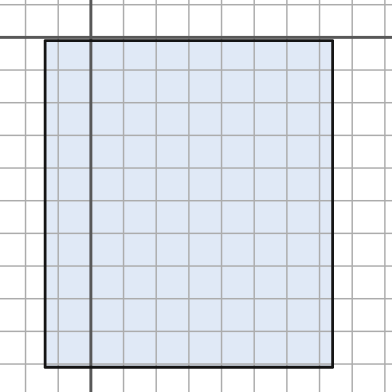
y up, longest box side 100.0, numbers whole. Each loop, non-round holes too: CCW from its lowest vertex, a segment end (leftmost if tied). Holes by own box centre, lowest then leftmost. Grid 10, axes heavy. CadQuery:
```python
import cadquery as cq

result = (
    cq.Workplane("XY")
    .moveTo(-14.0, -101.0)
    .lineTo(74.0, -101.0)
    .lineTo(74.0, -1.0)
    .lineTo(-14.0, -1.0)
    .close()
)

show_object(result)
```